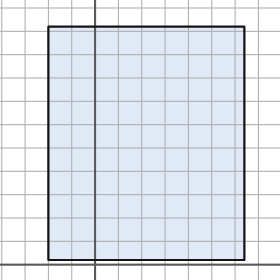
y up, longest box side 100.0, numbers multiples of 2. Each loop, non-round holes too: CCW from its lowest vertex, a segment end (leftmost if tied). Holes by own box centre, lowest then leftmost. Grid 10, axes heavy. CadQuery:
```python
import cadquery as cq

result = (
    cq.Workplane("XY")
    .moveTo(-20.0, 2.0)
    .lineTo(64.0, 2.0)
    .lineTo(64.0, 102.0)
    .lineTo(-20.0, 102.0)
    .close()
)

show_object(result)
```